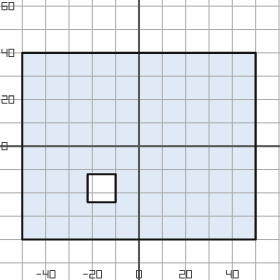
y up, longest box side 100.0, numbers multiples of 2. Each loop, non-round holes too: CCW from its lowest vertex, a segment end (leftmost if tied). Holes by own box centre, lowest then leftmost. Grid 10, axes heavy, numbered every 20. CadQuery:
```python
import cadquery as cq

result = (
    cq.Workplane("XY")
    .moveTo(-50.0, -40.0)
    .lineTo(50.0, -40.0)
    .lineTo(50.0, 40.0)
    .lineTo(-50.0, 40.0)
    .close()
    .moveTo(-22.0, -24.0)
    .lineTo(-10.0, -24.0)
    .lineTo(-10.0, -12.0)
    .lineTo(-22.0, -12.0)
    .close()
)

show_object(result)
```